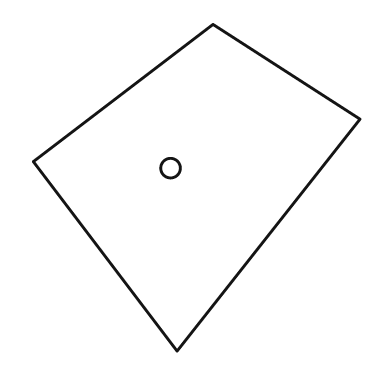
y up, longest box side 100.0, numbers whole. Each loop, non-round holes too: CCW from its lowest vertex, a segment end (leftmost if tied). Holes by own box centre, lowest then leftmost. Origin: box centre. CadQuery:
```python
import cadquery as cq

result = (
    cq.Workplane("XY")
    .moveTo(-6.0, -50.0)
    .lineTo(50.0, 21.0)
    .lineTo(5.0, 50.0)
    .lineTo(-50.0, 8.0)
    .close()
    .moveTo(-8.0, 6.0)
    .circle(3.0)
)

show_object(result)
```